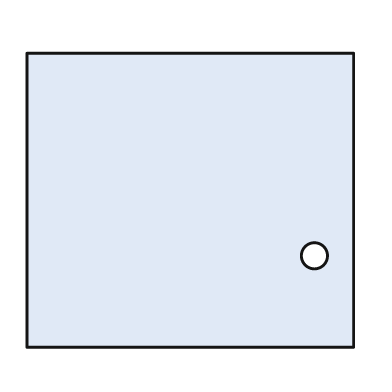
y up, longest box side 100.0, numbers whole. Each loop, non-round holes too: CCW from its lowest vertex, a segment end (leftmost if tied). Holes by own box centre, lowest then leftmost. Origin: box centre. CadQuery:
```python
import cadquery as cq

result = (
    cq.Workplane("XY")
    .moveTo(-50.0, -45.0)
    .lineTo(50.0, -45.0)
    .lineTo(50.0, 45.0)
    .lineTo(-50.0, 45.0)
    .close()
    .moveTo(38.0, -17.0)
    .circle(4.0)
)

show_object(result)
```